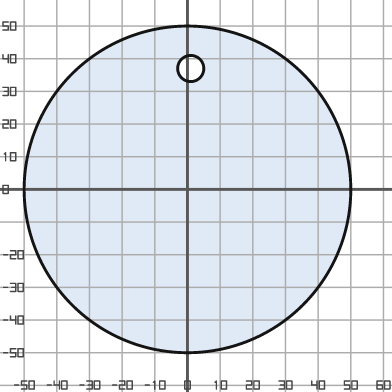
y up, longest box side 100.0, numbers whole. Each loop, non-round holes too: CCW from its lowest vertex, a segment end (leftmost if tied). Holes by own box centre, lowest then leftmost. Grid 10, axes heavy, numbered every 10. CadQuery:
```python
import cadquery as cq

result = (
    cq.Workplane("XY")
    .moveTo(0.0, 0.0)
    .circle(50.0)
    .moveTo(1.0, 37.0)
    .circle(4.0)
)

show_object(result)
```